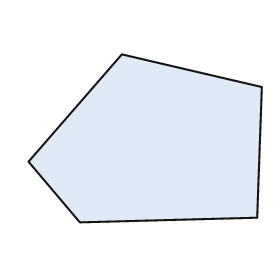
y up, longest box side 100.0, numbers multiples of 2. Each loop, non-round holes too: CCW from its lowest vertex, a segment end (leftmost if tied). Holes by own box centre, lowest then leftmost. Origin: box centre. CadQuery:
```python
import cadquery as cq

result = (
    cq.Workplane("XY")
    .moveTo(-28.0, -36.0)
    .lineTo(48.0, -34.0)
    .lineTo(50.0, 22.0)
    .lineTo(-10.0, 36.0)
    .lineTo(-50.0, -10.0)
    .close()
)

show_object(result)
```